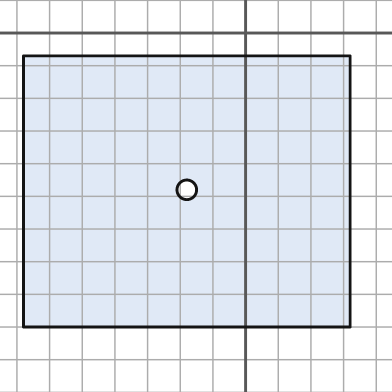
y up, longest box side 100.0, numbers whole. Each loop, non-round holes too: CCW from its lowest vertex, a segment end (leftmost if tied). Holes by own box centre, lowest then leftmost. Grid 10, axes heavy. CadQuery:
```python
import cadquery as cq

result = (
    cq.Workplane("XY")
    .moveTo(-68.0, -90.0)
    .lineTo(32.0, -90.0)
    .lineTo(32.0, -7.0)
    .lineTo(-68.0, -7.0)
    .close()
    .moveTo(-18.0, -48.0)
    .circle(3.0)
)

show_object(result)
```